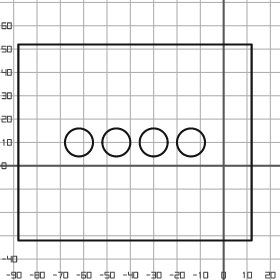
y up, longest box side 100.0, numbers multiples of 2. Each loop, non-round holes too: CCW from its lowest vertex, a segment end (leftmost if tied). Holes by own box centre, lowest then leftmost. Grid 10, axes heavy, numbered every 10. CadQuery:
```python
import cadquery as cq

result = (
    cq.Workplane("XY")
    .moveTo(-88.0, -32.0)
    .lineTo(12.0, -32.0)
    .lineTo(12.0, 52.0)
    .lineTo(-88.0, 52.0)
    .close()
    .moveTo(-62.0, 10.0)
    .circle(6.0)
    .moveTo(-46.0, 10.0)
    .circle(6.0)
    .moveTo(-30.0, 10.0)
    .circle(6.0)
    .moveTo(-14.0, 10.0)
    .circle(6.0)
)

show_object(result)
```